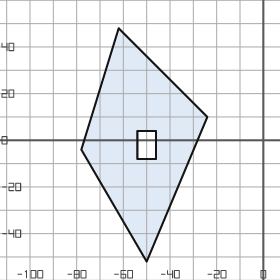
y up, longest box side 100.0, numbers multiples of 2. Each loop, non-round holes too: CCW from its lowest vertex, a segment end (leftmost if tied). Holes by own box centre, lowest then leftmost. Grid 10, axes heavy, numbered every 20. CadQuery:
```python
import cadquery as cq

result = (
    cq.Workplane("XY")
    .moveTo(-50.0, -52.0)
    .lineTo(-24.0, 10.0)
    .lineTo(-62.0, 48.0)
    .lineTo(-78.0, -4.0)
    .close()
    .moveTo(-54.0, -8.0)
    .lineTo(-46.0, -8.0)
    .lineTo(-46.0, 4.0)
    .lineTo(-54.0, 4.0)
    .close()
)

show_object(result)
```